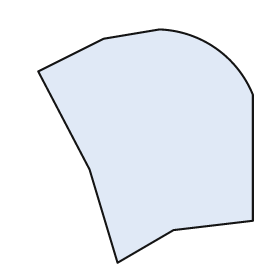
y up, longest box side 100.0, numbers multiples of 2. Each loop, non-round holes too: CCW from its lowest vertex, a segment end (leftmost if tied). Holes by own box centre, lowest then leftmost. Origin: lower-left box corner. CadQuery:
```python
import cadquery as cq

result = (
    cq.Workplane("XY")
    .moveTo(34.0, 0.0)
    .lineTo(58.0, 14.0)
    .lineTo(92.0, 18.0)
    .lineTo(92.0, 72.0)
    .threePointArc((76.0, 92.0), (52.0, 100.0))
    .lineTo(28.0, 96.0)
    .lineTo(0.0, 82.0)
    .lineTo(22.0, 40.0)
    .close()
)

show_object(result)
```